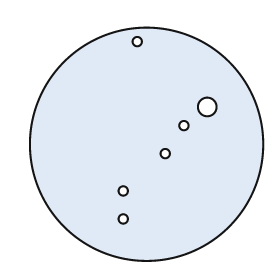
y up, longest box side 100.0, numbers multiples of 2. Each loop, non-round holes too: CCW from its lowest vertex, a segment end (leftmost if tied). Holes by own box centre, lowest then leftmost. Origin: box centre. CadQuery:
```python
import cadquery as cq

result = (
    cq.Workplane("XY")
    .moveTo(0.0, 0.0)
    .circle(50.0)
    .moveTo(-10.0, -32.0)
    .circle(2.0)
    .moveTo(-10.0, -20.0)
    .circle(2.0)
    .moveTo(8.0, -4.0)
    .circle(2.0)
    .moveTo(16.0, 8.0)
    .circle(2.0)
    .moveTo(26.0, 16.0)
    .circle(4.0)
    .moveTo(-4.0, 44.0)
    .circle(2.0)
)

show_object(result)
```